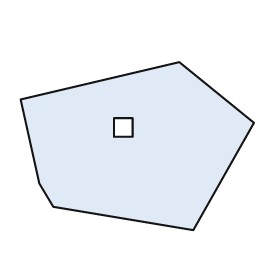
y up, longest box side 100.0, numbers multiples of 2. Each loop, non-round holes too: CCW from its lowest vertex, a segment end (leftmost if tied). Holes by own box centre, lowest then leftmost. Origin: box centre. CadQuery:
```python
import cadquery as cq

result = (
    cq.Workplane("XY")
    .moveTo(24.0, -36.0)
    .lineTo(50.0, 10.0)
    .lineTo(18.0, 36.0)
    .lineTo(-50.0, 20.0)
    .lineTo(-42.0, -16.0)
    .lineTo(-36.0, -26.0)
    .close()
    .moveTo(-10.0, 4.0)
    .lineTo(-2.0, 4.0)
    .lineTo(-2.0, 12.0)
    .lineTo(-10.0, 12.0)
    .close()
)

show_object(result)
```